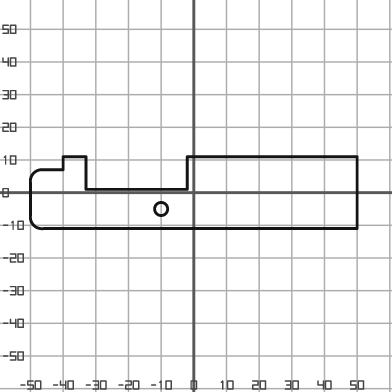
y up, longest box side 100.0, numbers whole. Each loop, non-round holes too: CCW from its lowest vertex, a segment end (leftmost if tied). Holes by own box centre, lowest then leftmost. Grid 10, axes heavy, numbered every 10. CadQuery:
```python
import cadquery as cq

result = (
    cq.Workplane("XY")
    .moveTo(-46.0, -11.0)
    .lineTo(50.0, -11.0)
    .lineTo(50.0, 11.0)
    .lineTo(-2.0, 11.0)
    .lineTo(-2.0, 1.0)
    .lineTo(-33.0, 1.0)
    .lineTo(-33.0, 11.0)
    .lineTo(-40.0, 11.0)
    .lineTo(-40.0, 7.0)
    .lineTo(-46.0, 7.0)
    .threePointArc((-49.0, 6.0), (-50.0, 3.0))
    .lineTo(-50.0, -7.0)
    .threePointArc((-49.0, -10.0), (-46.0, -11.0))
    .close()
    .moveTo(-10.0, -5.0)
    .circle(2.0)
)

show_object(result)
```